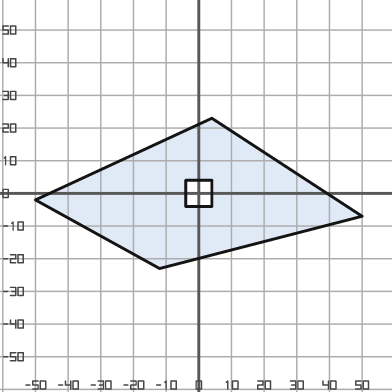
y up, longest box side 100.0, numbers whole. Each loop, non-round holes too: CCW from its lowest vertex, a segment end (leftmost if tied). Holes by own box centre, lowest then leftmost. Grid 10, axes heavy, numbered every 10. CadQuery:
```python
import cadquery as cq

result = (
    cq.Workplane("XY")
    .moveTo(-12.0, -23.0)
    .lineTo(50.0, -7.0)
    .lineTo(4.0, 23.0)
    .lineTo(-50.0, -2.0)
    .close()
    .moveTo(-4.0, -4.0)
    .lineTo(4.0, -4.0)
    .lineTo(4.0, 4.0)
    .lineTo(-4.0, 4.0)
    .close()
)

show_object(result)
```